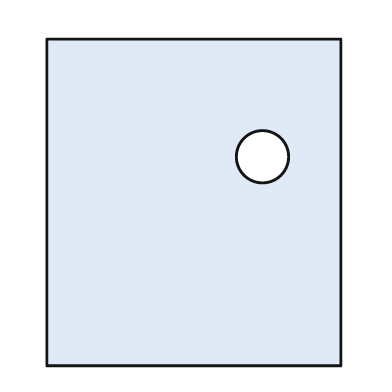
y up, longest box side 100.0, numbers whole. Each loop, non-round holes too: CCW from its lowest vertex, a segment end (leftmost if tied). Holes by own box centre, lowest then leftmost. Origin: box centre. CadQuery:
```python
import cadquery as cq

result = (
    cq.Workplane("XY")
    .moveTo(-45.0, -50.0)
    .lineTo(45.0, -50.0)
    .lineTo(45.0, 50.0)
    .lineTo(-45.0, 50.0)
    .close()
    .moveTo(21.0, 14.0)
    .circle(8.0)
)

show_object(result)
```